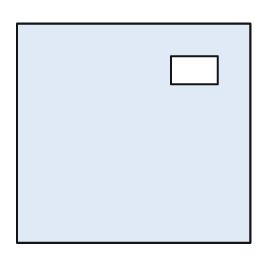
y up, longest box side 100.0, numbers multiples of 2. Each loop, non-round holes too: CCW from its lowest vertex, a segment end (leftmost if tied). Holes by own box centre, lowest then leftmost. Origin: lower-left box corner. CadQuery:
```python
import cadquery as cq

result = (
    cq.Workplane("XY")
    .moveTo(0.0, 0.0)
    .lineTo(100.0, 0.0)
    .lineTo(100.0, 94.0)
    .lineTo(0.0, 94.0)
    .close()
    .moveTo(66.0, 68.0)
    .lineTo(86.0, 68.0)
    .lineTo(86.0, 80.0)
    .lineTo(66.0, 80.0)
    .close()
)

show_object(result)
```